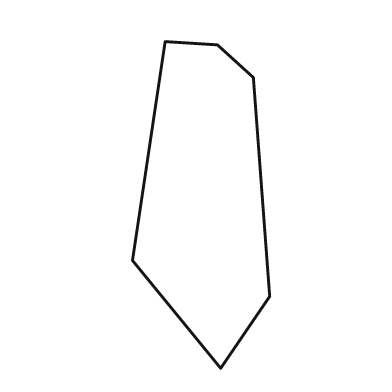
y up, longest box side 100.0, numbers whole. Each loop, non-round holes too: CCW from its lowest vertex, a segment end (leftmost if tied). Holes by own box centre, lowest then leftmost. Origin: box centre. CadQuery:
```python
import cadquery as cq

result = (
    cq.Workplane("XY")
    .moveTo(6.0, -50.0)
    .lineTo(21.0, -28.0)
    .lineTo(16.0, 39.0)
    .lineTo(5.0, 49.0)
    .lineTo(-11.0, 50.0)
    .lineTo(-21.0, -17.0)
    .close()
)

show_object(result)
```